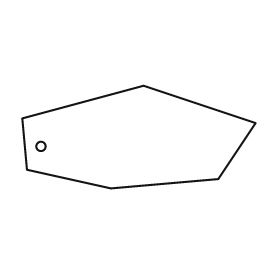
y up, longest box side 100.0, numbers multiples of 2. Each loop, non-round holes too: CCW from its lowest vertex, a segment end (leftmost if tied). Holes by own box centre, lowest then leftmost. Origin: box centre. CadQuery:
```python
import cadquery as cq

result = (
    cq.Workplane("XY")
    .moveTo(-12.0, -22.0)
    .lineTo(34.0, -18.0)
    .lineTo(50.0, 6.0)
    .lineTo(2.0, 22.0)
    .lineTo(-50.0, 8.0)
    .lineTo(-48.0, -14.0)
    .close()
    .moveTo(-42.0, -4.0)
    .circle(2.0)
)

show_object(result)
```